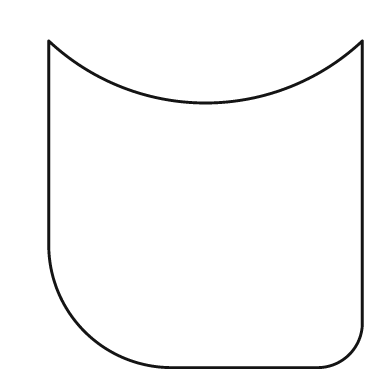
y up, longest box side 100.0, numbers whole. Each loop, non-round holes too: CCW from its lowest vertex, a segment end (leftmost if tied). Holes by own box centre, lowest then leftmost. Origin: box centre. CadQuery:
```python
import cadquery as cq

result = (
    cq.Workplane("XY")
    .moveTo(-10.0, -50.0)
    .lineTo(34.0, -50.0)
    .threePointArc((44.0, -46.0), (48.0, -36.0))
    .lineTo(48.0, 50.0)
    .threePointArc((0.0, 31.0), (-48.0, 50.0))
    .lineTo(-48.0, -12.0)
    .threePointArc((-37.0, -39.0), (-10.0, -50.0))
    .close()
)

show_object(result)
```